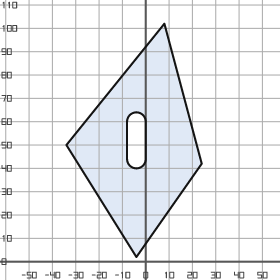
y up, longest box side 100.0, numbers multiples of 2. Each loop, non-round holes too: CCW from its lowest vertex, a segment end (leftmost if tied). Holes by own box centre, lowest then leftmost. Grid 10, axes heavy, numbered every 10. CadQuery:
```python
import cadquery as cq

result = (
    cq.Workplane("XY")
    .moveTo(-4.0, 2.0)
    .lineTo(24.0, 42.0)
    .lineTo(8.0, 102.0)
    .lineTo(-34.0, 50.0)
    .close()
    .moveTo(-8.0, 44.0)
    .threePointArc((-4.0, 40.0), (0.0, 44.0))
    .lineTo(0.0, 60.0)
    .threePointArc((-4.0, 64.0), (-8.0, 60.0))
    .close()
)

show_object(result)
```